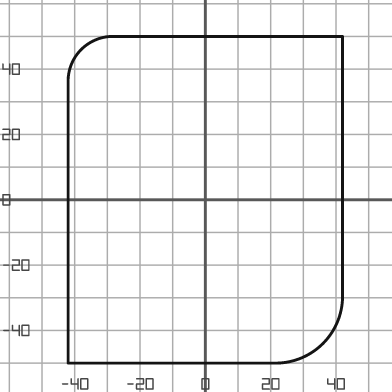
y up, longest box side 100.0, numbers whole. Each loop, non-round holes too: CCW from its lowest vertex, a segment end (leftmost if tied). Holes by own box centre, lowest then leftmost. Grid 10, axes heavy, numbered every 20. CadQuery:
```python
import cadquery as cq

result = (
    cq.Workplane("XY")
    .moveTo(-42.0, -50.0)
    .lineTo(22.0, -50.0)
    .threePointArc((36.0, -44.0), (42.0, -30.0))
    .lineTo(42.0, 50.0)
    .lineTo(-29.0, 50.0)
    .threePointArc((-38.0, 46.0), (-42.0, 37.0))
    .close()
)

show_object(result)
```